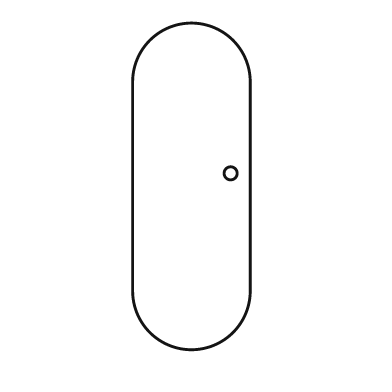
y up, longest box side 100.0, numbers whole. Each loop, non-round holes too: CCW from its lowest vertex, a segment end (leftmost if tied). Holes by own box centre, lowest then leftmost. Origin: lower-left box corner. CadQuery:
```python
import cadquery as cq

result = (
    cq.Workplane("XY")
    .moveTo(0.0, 18.0)
    .threePointArc((18.0, 0.0), (36.0, 18.0))
    .lineTo(36.0, 82.0)
    .threePointArc((18.0, 100.0), (0.0, 82.0))
    .close()
    .moveTo(30.0, 54.0)
    .circle(2.0)
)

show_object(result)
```